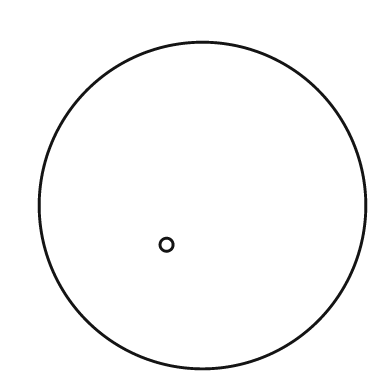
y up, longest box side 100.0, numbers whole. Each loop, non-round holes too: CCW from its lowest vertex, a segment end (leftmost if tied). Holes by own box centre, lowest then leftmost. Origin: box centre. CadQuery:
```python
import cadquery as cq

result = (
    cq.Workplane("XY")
    .moveTo(0.0, 0.0)
    .circle(50.0)
    .moveTo(-11.0, -12.0)
    .circle(2.0)
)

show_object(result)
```